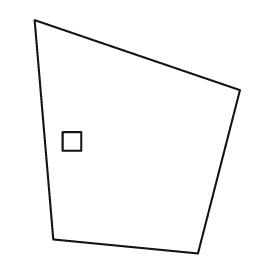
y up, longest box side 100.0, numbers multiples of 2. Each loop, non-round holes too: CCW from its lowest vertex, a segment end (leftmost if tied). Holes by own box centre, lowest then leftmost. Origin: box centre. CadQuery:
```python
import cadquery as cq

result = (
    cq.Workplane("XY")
    .moveTo(26.0, -50.0)
    .lineTo(44.0, 20.0)
    .lineTo(-44.0, 50.0)
    .lineTo(-36.0, -44.0)
    .close()
    .moveTo(-32.0, -6.0)
    .lineTo(-24.0, -6.0)
    .lineTo(-24.0, 2.0)
    .lineTo(-32.0, 2.0)
    .close()
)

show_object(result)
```